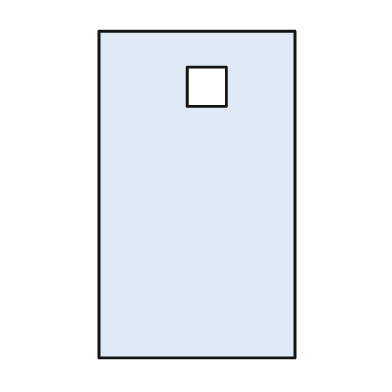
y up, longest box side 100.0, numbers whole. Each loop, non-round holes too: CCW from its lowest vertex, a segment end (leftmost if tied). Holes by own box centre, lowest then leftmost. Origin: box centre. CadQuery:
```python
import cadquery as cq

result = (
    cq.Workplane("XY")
    .moveTo(-30.0, -50.0)
    .lineTo(30.0, -50.0)
    .lineTo(30.0, 50.0)
    .lineTo(-30.0, 50.0)
    .close()
    .moveTo(-3.0, 27.0)
    .lineTo(9.0, 27.0)
    .lineTo(9.0, 39.0)
    .lineTo(-3.0, 39.0)
    .close()
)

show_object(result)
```